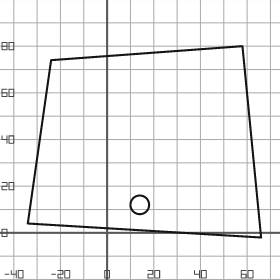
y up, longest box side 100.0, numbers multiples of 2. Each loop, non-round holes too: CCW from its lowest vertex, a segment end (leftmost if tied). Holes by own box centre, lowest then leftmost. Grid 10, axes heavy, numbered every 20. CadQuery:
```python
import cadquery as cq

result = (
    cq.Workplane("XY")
    .moveTo(66.0, -2.0)
    .lineTo(58.0, 80.0)
    .lineTo(-24.0, 74.0)
    .lineTo(-34.0, 4.0)
    .close()
    .moveTo(14.0, 12.0)
    .circle(4.0)
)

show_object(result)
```